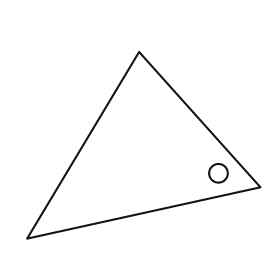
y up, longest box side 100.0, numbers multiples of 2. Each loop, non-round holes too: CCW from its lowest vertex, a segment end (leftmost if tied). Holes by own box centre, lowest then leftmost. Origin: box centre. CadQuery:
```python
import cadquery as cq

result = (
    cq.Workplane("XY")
    .moveTo(-50.0, -40.0)
    .lineTo(50.0, -18.0)
    .lineTo(-2.0, 40.0)
    .close()
    .moveTo(32.0, -12.0)
    .circle(4.0)
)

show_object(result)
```